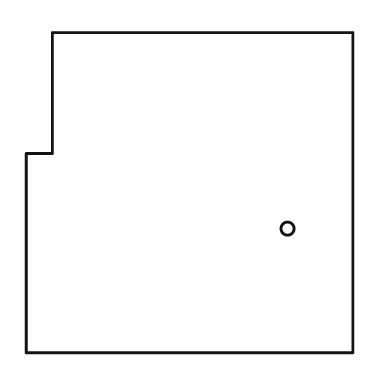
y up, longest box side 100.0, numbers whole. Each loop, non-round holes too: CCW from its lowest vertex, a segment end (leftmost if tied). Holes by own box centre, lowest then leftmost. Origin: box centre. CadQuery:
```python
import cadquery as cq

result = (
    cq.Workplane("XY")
    .moveTo(-50.0, -49.0)
    .lineTo(50.0, -49.0)
    .lineTo(50.0, 49.0)
    .lineTo(-42.0, 49.0)
    .lineTo(-42.0, 12.0)
    .lineTo(-50.0, 12.0)
    .close()
    .moveTo(30.0, -11.0)
    .circle(2.0)
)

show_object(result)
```